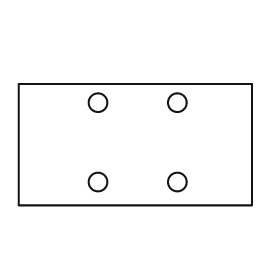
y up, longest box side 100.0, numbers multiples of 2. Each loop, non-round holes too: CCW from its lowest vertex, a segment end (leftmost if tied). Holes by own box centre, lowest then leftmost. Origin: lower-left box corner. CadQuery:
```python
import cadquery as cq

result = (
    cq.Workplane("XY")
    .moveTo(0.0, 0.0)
    .lineTo(100.0, 0.0)
    .lineTo(100.0, 52.0)
    .lineTo(0.0, 52.0)
    .close()
    .moveTo(34.0, 10.0)
    .circle(4.0)
    .moveTo(68.0, 10.0)
    .circle(4.0)
    .moveTo(34.0, 44.0)
    .circle(4.0)
    .moveTo(68.0, 44.0)
    .circle(4.0)
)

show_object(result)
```